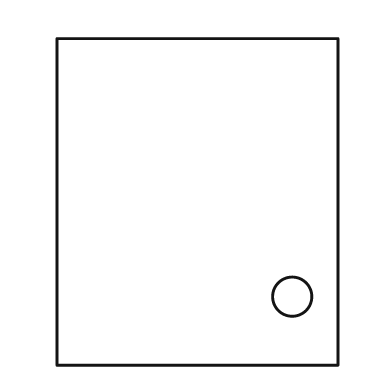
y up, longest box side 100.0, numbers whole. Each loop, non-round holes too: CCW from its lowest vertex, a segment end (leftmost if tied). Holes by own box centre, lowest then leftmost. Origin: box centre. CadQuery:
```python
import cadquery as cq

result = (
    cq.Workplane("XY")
    .moveTo(-43.0, -50.0)
    .lineTo(43.0, -50.0)
    .lineTo(43.0, 50.0)
    .lineTo(-43.0, 50.0)
    .close()
    .moveTo(29.0, -29.0)
    .circle(6.0)
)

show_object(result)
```